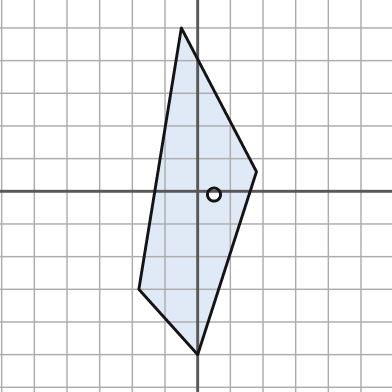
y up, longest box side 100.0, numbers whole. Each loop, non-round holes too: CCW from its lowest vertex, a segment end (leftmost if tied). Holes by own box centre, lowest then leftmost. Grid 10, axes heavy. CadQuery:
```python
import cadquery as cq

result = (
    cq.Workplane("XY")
    .moveTo(0.0, -50.0)
    .lineTo(18.0, 6.0)
    .lineTo(-5.0, 50.0)
    .lineTo(-18.0, -30.0)
    .close()
    .moveTo(5.0, -1.0)
    .circle(2.0)
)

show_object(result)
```